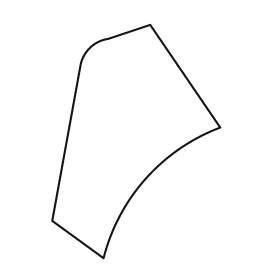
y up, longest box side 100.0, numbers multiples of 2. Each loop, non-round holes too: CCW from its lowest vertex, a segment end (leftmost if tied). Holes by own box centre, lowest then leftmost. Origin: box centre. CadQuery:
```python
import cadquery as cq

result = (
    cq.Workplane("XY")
    .moveTo(-14.0, -50.0)
    .threePointArc((4.0, -16.0), (36.0, 6.0))
    .lineTo(6.0, 50.0)
    .lineTo(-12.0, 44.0)
    .threePointArc((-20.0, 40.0), (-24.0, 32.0))
    .lineTo(-36.0, -34.0)
    .close()
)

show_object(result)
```